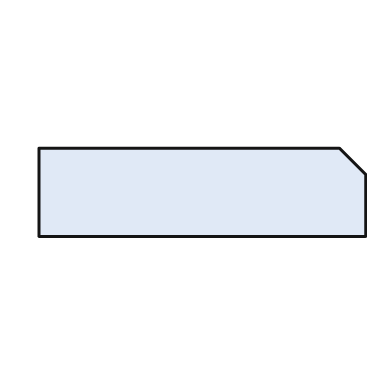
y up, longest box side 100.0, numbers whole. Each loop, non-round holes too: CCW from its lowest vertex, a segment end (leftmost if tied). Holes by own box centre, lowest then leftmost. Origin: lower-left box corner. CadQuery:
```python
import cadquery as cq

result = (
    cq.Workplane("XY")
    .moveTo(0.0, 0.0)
    .lineTo(100.0, 0.0)
    .lineTo(100.0, 19.0)
    .lineTo(92.0, 27.0)
    .lineTo(0.0, 27.0)
    .close()
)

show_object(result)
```